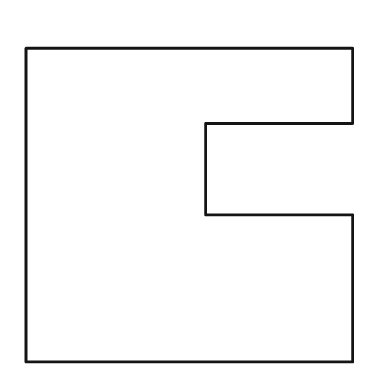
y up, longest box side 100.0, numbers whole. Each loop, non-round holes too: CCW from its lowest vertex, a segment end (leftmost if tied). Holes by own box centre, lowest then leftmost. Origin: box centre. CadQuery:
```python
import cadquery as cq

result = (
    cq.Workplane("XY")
    .moveTo(-50.0, -48.0)
    .lineTo(50.0, -48.0)
    .lineTo(50.0, -3.0)
    .lineTo(5.0, -3.0)
    .lineTo(5.0, 25.0)
    .lineTo(50.0, 25.0)
    .lineTo(50.0, 48.0)
    .lineTo(-50.0, 48.0)
    .close()
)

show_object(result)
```